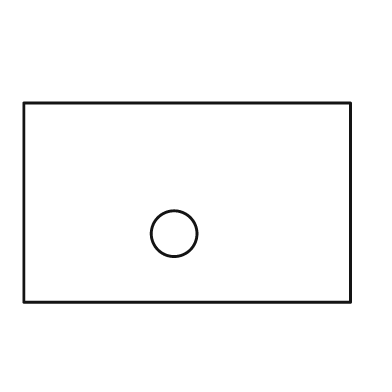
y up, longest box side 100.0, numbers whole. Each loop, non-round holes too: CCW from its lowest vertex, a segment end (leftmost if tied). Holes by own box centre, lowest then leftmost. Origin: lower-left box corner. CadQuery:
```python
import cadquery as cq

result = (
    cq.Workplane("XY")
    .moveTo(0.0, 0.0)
    .lineTo(100.0, 0.0)
    .lineTo(100.0, 61.0)
    .lineTo(0.0, 61.0)
    .close()
    .moveTo(46.0, 21.0)
    .circle(7.0)
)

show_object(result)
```